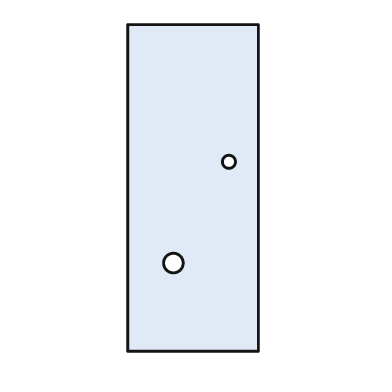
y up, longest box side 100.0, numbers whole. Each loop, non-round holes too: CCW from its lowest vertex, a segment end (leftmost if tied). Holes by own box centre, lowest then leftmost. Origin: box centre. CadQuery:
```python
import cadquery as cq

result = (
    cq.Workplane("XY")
    .moveTo(-20.0, -50.0)
    .lineTo(20.0, -50.0)
    .lineTo(20.0, 50.0)
    .lineTo(-20.0, 50.0)
    .close()
    .moveTo(-6.0, -23.0)
    .circle(3.0)
    .moveTo(11.0, 8.0)
    .circle(2.0)
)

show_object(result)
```